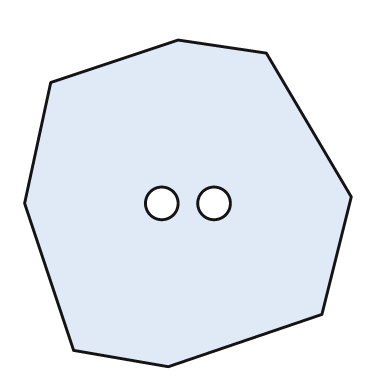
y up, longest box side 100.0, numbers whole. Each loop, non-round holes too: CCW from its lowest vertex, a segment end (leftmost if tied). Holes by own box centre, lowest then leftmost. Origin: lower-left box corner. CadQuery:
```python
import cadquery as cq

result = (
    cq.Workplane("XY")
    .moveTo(44.0, 0.0)
    .lineTo(91.0, 16.0)
    .lineTo(100.0, 52.0)
    .lineTo(74.0, 96.0)
    .lineTo(47.0, 100.0)
    .lineTo(8.0, 87.0)
    .lineTo(0.0, 50.0)
    .lineTo(15.0, 5.0)
    .close()
    .moveTo(42.0, 50.0)
    .circle(5.0)
    .moveTo(58.0, 50.0)
    .circle(5.0)
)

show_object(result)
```